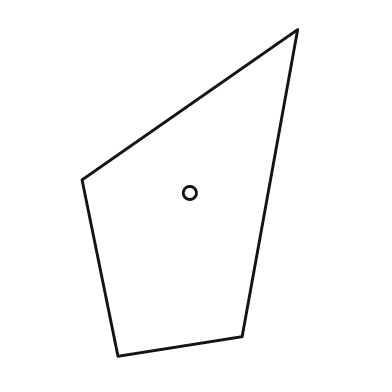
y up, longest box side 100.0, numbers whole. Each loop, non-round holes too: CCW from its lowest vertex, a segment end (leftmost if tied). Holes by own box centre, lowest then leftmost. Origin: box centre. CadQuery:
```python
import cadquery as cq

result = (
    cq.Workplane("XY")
    .moveTo(-22.0, -50.0)
    .lineTo(16.0, -44.0)
    .lineTo(33.0, 50.0)
    .lineTo(-33.0, 4.0)
    .close()
    .moveTo(0.0, 0.0)
    .circle(2.0)
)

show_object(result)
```